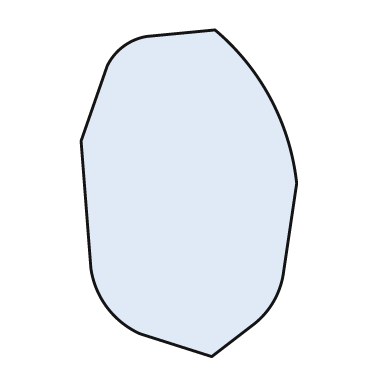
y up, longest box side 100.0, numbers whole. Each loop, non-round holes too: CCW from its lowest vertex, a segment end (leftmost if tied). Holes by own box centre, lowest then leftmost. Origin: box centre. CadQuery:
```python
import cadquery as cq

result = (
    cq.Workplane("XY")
    .moveTo(7.0, -50.0)
    .lineTo(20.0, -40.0)
    .threePointArc((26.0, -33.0), (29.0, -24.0))
    .lineTo(33.0, 3.0)
    .threePointArc((25.0, 29.0), (8.0, 50.0))
    .lineTo(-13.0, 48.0)
    .threePointArc((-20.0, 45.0), (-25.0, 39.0))
    .lineTo(-33.0, 16.0)
    .lineTo(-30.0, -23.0)
    .threePointArc((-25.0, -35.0), (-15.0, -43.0))
    .close()
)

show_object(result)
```